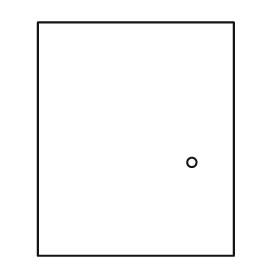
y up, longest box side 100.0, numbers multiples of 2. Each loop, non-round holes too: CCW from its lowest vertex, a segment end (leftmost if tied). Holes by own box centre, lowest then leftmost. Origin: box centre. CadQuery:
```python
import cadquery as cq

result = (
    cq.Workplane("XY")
    .moveTo(-42.0, -50.0)
    .lineTo(42.0, -50.0)
    .lineTo(42.0, 50.0)
    .lineTo(-42.0, 50.0)
    .close()
    .moveTo(24.0, -10.0)
    .circle(2.0)
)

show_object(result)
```